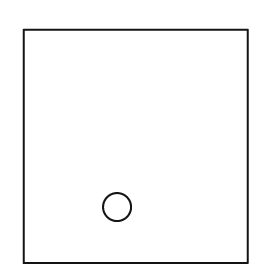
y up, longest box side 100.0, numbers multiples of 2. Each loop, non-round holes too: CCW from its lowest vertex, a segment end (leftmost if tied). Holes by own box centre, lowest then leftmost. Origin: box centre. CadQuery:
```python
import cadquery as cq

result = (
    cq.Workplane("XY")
    .moveTo(-48.0, -50.0)
    .lineTo(48.0, -50.0)
    .lineTo(48.0, 50.0)
    .lineTo(-48.0, 50.0)
    .close()
    .moveTo(-8.0, -26.0)
    .circle(6.0)
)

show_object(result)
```